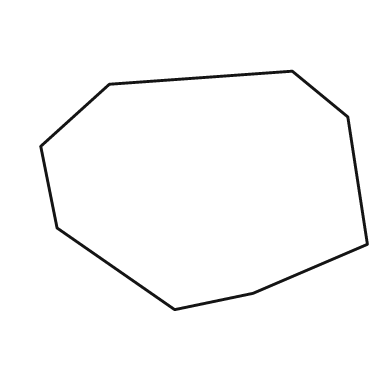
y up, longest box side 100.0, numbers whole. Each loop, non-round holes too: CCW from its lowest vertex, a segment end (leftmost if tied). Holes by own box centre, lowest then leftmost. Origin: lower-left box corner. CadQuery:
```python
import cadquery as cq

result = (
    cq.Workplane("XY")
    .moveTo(41.0, 0.0)
    .lineTo(65.0, 5.0)
    .lineTo(100.0, 20.0)
    .lineTo(94.0, 59.0)
    .lineTo(77.0, 73.0)
    .lineTo(21.0, 69.0)
    .lineTo(0.0, 50.0)
    .lineTo(5.0, 25.0)
    .close()
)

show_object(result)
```